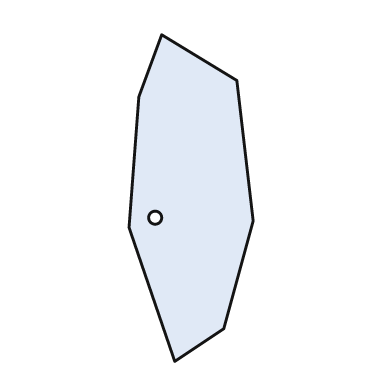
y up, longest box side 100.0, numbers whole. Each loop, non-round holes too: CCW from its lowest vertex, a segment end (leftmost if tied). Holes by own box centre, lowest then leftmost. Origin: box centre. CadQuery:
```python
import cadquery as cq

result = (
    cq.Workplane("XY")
    .moveTo(-5.0, -50.0)
    .lineTo(10.0, -40.0)
    .lineTo(19.0, -7.0)
    .lineTo(14.0, 36.0)
    .lineTo(-9.0, 50.0)
    .lineTo(-16.0, 31.0)
    .lineTo(-19.0, -9.0)
    .close()
    .moveTo(-11.0, -6.0)
    .circle(2.0)
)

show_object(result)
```